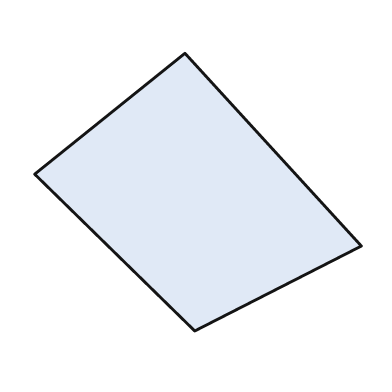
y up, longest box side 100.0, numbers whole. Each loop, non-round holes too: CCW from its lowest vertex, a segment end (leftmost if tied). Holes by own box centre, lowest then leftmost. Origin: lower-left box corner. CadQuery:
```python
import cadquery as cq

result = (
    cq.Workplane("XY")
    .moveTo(49.0, 0.0)
    .lineTo(100.0, 26.0)
    .lineTo(46.0, 85.0)
    .lineTo(0.0, 48.0)
    .close()
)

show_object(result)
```